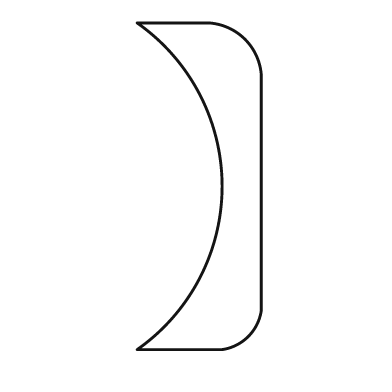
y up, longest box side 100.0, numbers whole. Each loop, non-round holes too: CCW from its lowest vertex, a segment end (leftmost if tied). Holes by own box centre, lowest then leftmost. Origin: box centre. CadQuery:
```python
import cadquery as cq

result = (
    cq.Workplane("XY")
    .moveTo(-19.0, -50.0)
    .lineTo(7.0, -50.0)
    .threePointArc((15.0, -46.0), (19.0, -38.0))
    .lineTo(19.0, 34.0)
    .threePointArc((14.0, 45.0), (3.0, 50.0))
    .lineTo(-19.0, 50.0)
    .threePointArc((7.0, 0.0), (-19.0, -50.0))
    .close()
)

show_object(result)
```